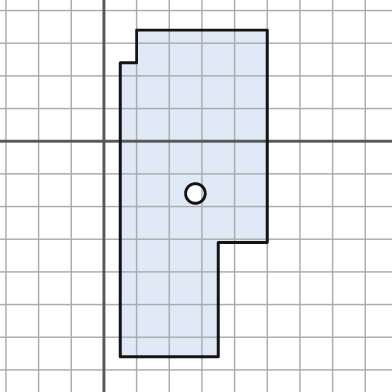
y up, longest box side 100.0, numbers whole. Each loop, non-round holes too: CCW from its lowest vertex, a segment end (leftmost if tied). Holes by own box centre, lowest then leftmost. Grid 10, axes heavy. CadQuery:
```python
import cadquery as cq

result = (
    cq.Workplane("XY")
    .moveTo(5.0, -66.0)
    .lineTo(35.0, -66.0)
    .lineTo(35.0, -31.0)
    .lineTo(50.0, -31.0)
    .lineTo(50.0, 34.0)
    .lineTo(10.0, 34.0)
    .lineTo(10.0, 24.0)
    .lineTo(5.0, 24.0)
    .close()
    .moveTo(28.0, -16.0)
    .circle(3.0)
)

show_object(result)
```